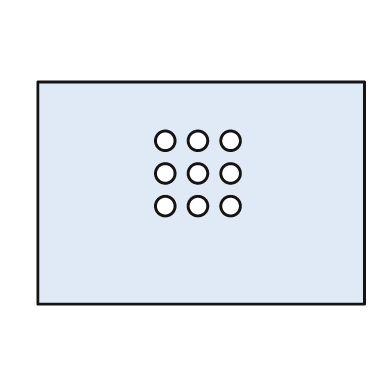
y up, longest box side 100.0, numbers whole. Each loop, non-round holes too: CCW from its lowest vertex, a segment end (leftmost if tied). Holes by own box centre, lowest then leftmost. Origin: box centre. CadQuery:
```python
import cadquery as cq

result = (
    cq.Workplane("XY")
    .moveTo(-50.0, -34.0)
    .lineTo(50.0, -34.0)
    .lineTo(50.0, 34.0)
    .lineTo(-50.0, 34.0)
    .close()
    .moveTo(-11.0, -4.0)
    .circle(3.0)
    .moveTo(-1.0, -4.0)
    .circle(3.0)
    .moveTo(9.0, -4.0)
    .circle(3.0)
    .moveTo(-11.0, 6.0)
    .circle(3.0)
    .moveTo(-1.0, 6.0)
    .circle(3.0)
    .moveTo(9.0, 6.0)
    .circle(3.0)
    .moveTo(-11.0, 16.0)
    .circle(3.0)
    .moveTo(-1.0, 16.0)
    .circle(3.0)
    .moveTo(9.0, 16.0)
    .circle(3.0)
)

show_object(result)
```